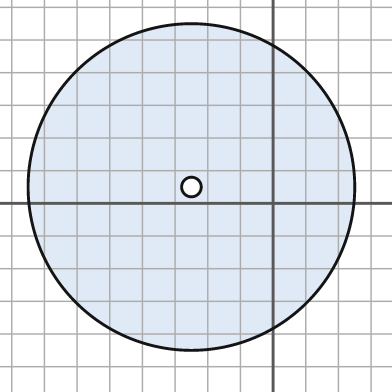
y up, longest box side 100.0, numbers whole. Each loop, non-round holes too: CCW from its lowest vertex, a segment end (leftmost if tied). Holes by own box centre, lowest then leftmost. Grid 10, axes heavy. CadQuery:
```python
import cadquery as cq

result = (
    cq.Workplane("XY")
    .moveTo(-25.0, 5.0)
    .circle(50.0)
    .moveTo(-25.0, 5.0)
    .circle(3.0)
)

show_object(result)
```